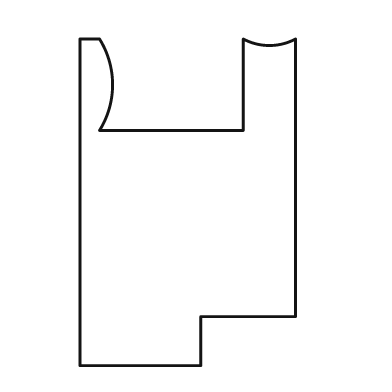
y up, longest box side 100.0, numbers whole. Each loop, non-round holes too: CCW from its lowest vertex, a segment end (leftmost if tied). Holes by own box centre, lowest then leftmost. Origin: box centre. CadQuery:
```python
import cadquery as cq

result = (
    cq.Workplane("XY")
    .moveTo(-33.0, -50.0)
    .lineTo(4.0, -50.0)
    .lineTo(4.0, -35.0)
    .lineTo(33.0, -35.0)
    .lineTo(33.0, 50.0)
    .threePointArc((25.0, 48.0), (17.0, 50.0))
    .lineTo(17.0, 22.0)
    .lineTo(-27.0, 22.0)
    .threePointArc((-23.0, 36.0), (-27.0, 50.0))
    .lineTo(-33.0, 50.0)
    .close()
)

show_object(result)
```